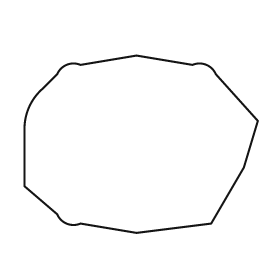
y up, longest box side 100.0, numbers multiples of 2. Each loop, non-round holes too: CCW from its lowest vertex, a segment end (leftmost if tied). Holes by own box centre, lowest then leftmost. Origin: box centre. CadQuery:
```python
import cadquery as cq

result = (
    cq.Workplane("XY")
    .moveTo(-2.0, -38.0)
    .lineTo(30.0, -34.0)
    .lineTo(44.0, -10.0)
    .lineTo(50.0, 10.0)
    .lineTo(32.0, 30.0)
    .threePointArc((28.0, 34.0), (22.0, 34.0))
    .lineTo(-2.0, 38.0)
    .lineTo(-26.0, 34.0)
    .threePointArc((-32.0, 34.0), (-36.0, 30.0))
    .lineTo(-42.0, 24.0)
    .threePointArc((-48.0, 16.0), (-50.0, 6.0))
    .lineTo(-50.0, -18.0)
    .lineTo(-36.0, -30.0)
    .threePointArc((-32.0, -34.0), (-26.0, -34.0))
    .close()
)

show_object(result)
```